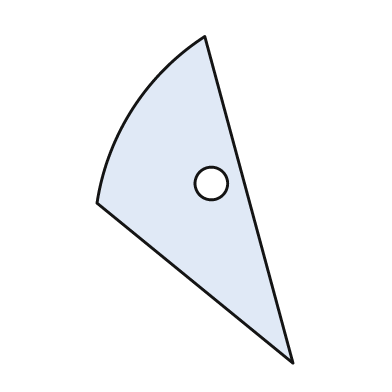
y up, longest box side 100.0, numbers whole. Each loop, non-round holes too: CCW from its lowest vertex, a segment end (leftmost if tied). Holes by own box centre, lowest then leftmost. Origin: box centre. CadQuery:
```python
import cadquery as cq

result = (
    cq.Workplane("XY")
    .moveTo(30.0, -50.0)
    .lineTo(3.0, 50.0)
    .threePointArc((-19.0, 28.0), (-30.0, -1.0))
    .close()
    .moveTo(5.0, 5.0)
    .circle(5.0)
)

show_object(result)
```